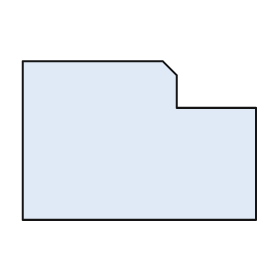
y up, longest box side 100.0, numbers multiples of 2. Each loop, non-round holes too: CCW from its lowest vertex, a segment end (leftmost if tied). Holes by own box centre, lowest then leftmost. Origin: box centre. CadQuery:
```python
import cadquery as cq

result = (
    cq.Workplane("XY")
    .moveTo(-50.0, -34.0)
    .lineTo(50.0, -34.0)
    .lineTo(50.0, 14.0)
    .lineTo(16.0, 14.0)
    .lineTo(16.0, 28.0)
    .lineTo(10.0, 34.0)
    .lineTo(-50.0, 34.0)
    .close()
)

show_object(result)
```